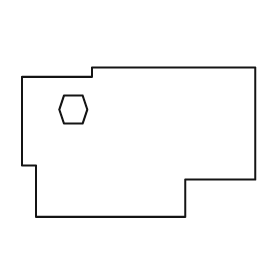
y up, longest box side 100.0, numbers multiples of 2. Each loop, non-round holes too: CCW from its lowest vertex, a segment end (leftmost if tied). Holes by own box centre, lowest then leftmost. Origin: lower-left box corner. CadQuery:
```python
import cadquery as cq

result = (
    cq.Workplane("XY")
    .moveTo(6.0, 0.0)
    .lineTo(70.0, 0.0)
    .lineTo(70.0, 16.0)
    .lineTo(100.0, 16.0)
    .lineTo(100.0, 64.0)
    .lineTo(30.0, 64.0)
    .lineTo(30.0, 60.0)
    .lineTo(0.0, 60.0)
    .lineTo(0.0, 22.0)
    .lineTo(6.0, 22.0)
    .close()
    .moveTo(18.0, 40.0)
    .lineTo(26.0, 40.0)
    .lineTo(28.0, 46.0)
    .lineTo(26.0, 52.0)
    .lineTo(18.0, 52.0)
    .lineTo(16.0, 46.0)
    .close()
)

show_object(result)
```